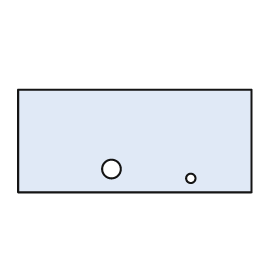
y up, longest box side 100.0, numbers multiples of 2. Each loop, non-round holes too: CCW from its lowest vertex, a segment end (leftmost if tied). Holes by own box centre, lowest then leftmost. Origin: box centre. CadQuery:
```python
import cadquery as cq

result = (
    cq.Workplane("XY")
    .moveTo(-50.0, -22.0)
    .lineTo(50.0, -22.0)
    .lineTo(50.0, 22.0)
    .lineTo(-50.0, 22.0)
    .close()
    .moveTo(24.0, -16.0)
    .circle(2.0)
    .moveTo(-10.0, -12.0)
    .circle(4.0)
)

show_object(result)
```